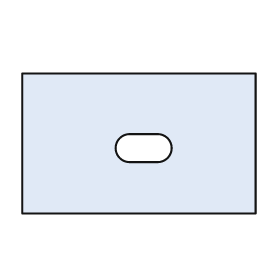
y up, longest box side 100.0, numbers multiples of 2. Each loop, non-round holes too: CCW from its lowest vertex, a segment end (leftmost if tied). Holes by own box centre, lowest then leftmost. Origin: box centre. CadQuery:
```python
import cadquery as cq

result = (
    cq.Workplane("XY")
    .moveTo(-50.0, -30.0)
    .lineTo(50.0, -30.0)
    .lineTo(50.0, 30.0)
    .lineTo(-50.0, 30.0)
    .close()
    .moveTo(-4.0, -8.0)
    .lineTo(8.0, -8.0)
    .threePointArc((14.0, -2.0), (8.0, 4.0))
    .lineTo(-4.0, 4.0)
    .threePointArc((-10.0, -2.0), (-4.0, -8.0))
    .close()
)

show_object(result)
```